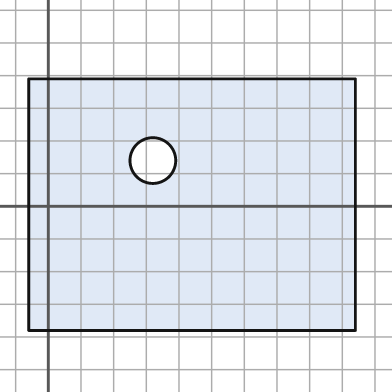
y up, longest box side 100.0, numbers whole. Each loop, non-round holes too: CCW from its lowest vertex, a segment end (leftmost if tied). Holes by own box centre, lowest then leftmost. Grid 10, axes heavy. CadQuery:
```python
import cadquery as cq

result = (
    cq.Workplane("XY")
    .moveTo(-6.0, -38.0)
    .lineTo(94.0, -38.0)
    .lineTo(94.0, 39.0)
    .lineTo(-6.0, 39.0)
    .close()
    .moveTo(32.0, 14.0)
    .circle(7.0)
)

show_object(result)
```